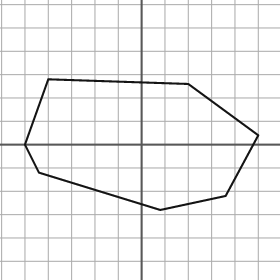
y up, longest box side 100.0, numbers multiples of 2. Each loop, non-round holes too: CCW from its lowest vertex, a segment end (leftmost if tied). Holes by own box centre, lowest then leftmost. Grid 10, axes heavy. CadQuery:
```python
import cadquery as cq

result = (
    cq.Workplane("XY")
    .moveTo(8.0, -28.0)
    .lineTo(36.0, -22.0)
    .lineTo(50.0, 4.0)
    .lineTo(20.0, 26.0)
    .lineTo(-40.0, 28.0)
    .lineTo(-50.0, 0.0)
    .lineTo(-44.0, -12.0)
    .close()
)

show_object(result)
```